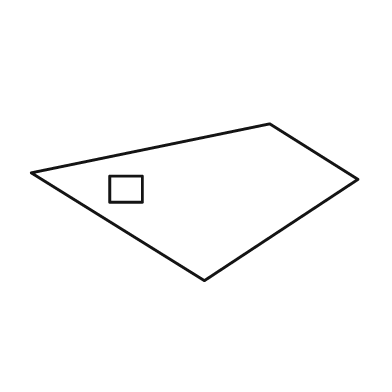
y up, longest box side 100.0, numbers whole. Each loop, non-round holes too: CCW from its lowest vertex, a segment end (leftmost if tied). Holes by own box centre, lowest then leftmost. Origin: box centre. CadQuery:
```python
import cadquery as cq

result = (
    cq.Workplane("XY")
    .moveTo(3.0, -24.0)
    .lineTo(50.0, 7.0)
    .lineTo(23.0, 24.0)
    .lineTo(-50.0, 9.0)
    .close()
    .moveTo(-26.0, 0.0)
    .lineTo(-16.0, 0.0)
    .lineTo(-16.0, 8.0)
    .lineTo(-26.0, 8.0)
    .close()
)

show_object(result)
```